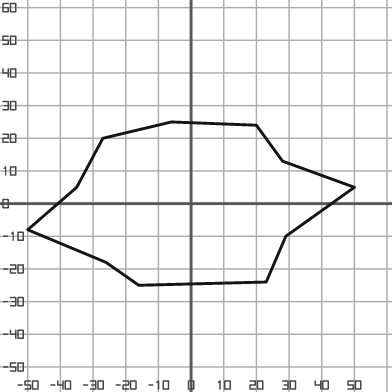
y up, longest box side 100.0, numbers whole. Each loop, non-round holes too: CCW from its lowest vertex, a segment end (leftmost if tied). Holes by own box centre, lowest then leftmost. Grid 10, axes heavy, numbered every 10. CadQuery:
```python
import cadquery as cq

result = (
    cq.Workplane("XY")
    .moveTo(-16.0, -25.0)
    .lineTo(23.0, -24.0)
    .lineTo(29.0, -10.0)
    .lineTo(50.0, 5.0)
    .lineTo(28.0, 13.0)
    .lineTo(20.0, 24.0)
    .lineTo(-6.0, 25.0)
    .lineTo(-27.0, 20.0)
    .lineTo(-35.0, 5.0)
    .lineTo(-50.0, -8.0)
    .lineTo(-26.0, -18.0)
    .close()
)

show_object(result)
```